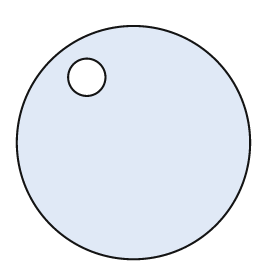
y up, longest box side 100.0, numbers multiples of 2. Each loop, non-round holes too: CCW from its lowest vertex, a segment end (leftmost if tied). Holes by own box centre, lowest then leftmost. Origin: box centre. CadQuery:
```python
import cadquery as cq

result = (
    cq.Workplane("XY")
    .moveTo(0.0, 0.0)
    .circle(50.0)
    .moveTo(-20.0, 28.0)
    .circle(8.0)
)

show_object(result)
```